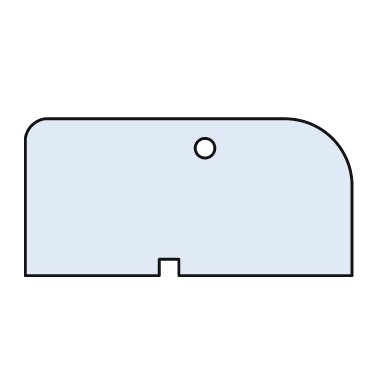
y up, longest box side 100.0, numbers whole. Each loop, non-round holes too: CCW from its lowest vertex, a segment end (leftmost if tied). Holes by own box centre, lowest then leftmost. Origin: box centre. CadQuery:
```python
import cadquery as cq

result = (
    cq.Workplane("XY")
    .moveTo(-50.0, -24.0)
    .lineTo(-9.0, -24.0)
    .lineTo(-9.0, -19.0)
    .lineTo(-3.0, -19.0)
    .lineTo(-3.0, -24.0)
    .lineTo(50.0, -24.0)
    .lineTo(50.0, 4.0)
    .threePointArc((44.0, 18.0), (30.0, 24.0))
    .lineTo(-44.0, 24.0)
    .threePointArc((-48.0, 22.0), (-50.0, 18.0))
    .close()
    .moveTo(5.0, 15.0)
    .circle(3.0)
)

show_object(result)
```